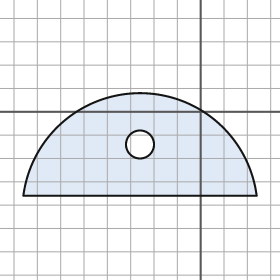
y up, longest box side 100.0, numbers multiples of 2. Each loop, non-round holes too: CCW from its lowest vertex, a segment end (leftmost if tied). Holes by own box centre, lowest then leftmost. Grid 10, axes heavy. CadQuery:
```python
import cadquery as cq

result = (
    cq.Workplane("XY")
    .moveTo(-76.0, -36.0)
    .lineTo(24.0, -36.0)
    .threePointArc((-26.0, 8.0), (-76.0, -36.0))
    .close()
    .moveTo(-26.0, -14.0)
    .circle(6.0)
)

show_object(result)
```